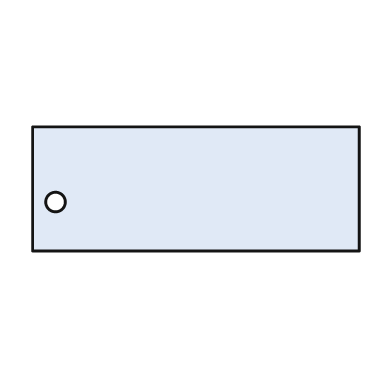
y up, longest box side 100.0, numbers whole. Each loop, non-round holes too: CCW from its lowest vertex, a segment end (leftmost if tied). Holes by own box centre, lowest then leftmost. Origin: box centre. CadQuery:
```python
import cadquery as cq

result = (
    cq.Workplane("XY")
    .moveTo(-50.0, -19.0)
    .lineTo(50.0, -19.0)
    .lineTo(50.0, 19.0)
    .lineTo(-50.0, 19.0)
    .close()
    .moveTo(-43.0, -4.0)
    .circle(3.0)
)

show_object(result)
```